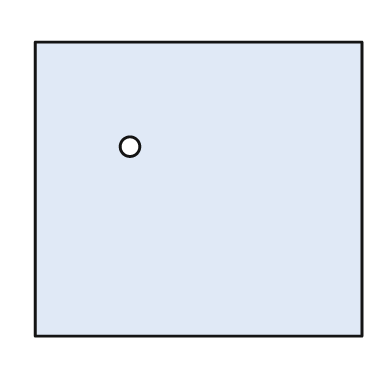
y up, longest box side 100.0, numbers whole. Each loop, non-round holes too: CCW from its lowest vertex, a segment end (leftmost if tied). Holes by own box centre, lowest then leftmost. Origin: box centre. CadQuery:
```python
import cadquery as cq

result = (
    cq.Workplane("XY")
    .moveTo(-50.0, -45.0)
    .lineTo(50.0, -45.0)
    .lineTo(50.0, 45.0)
    .lineTo(-50.0, 45.0)
    .close()
    .moveTo(-21.0, 13.0)
    .circle(3.0)
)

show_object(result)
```